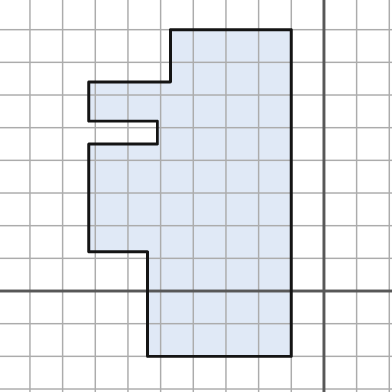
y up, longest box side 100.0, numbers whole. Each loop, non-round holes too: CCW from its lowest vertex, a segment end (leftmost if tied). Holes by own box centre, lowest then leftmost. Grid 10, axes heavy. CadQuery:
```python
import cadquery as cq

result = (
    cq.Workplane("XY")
    .moveTo(-54.0, -20.0)
    .lineTo(-10.0, -20.0)
    .lineTo(-10.0, 80.0)
    .lineTo(-47.0, 80.0)
    .lineTo(-47.0, 64.0)
    .lineTo(-72.0, 64.0)
    .lineTo(-72.0, 52.0)
    .lineTo(-51.0, 52.0)
    .lineTo(-51.0, 45.0)
    .lineTo(-72.0, 45.0)
    .lineTo(-72.0, 12.0)
    .lineTo(-54.0, 12.0)
    .close()
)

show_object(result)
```